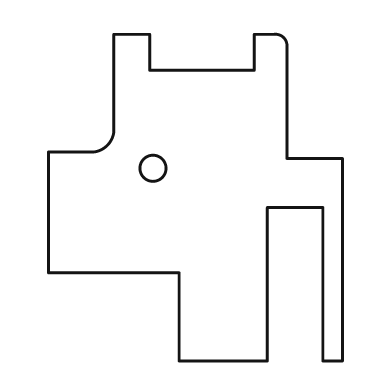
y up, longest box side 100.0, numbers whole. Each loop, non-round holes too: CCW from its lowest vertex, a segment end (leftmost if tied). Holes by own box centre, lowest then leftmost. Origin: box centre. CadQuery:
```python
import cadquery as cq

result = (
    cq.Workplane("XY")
    .moveTo(-5.0, -50.0)
    .lineTo(22.0, -50.0)
    .lineTo(22.0, -3.0)
    .lineTo(39.0, -3.0)
    .lineTo(39.0, -50.0)
    .lineTo(45.0, -50.0)
    .lineTo(45.0, 12.0)
    .lineTo(28.0, 12.0)
    .lineTo(28.0, 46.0)
    .threePointArc((27.0, 49.0), (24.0, 50.0))
    .lineTo(18.0, 50.0)
    .lineTo(18.0, 39.0)
    .lineTo(-14.0, 39.0)
    .lineTo(-14.0, 50.0)
    .lineTo(-25.0, 50.0)
    .lineTo(-25.0, 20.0)
    .threePointArc((-27.0, 16.0), (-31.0, 14.0))
    .lineTo(-45.0, 14.0)
    .lineTo(-45.0, -23.0)
    .lineTo(-5.0, -23.0)
    .close()
    .moveTo(-13.0, 9.0)
    .circle(4.0)
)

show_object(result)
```